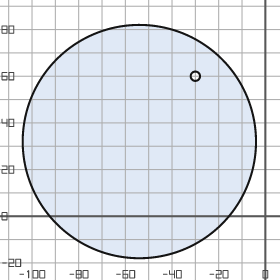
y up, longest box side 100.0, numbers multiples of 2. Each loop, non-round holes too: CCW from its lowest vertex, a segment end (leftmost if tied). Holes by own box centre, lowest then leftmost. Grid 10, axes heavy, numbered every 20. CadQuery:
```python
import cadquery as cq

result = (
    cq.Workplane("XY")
    .moveTo(-54.0, 32.0)
    .circle(50.0)
    .moveTo(-30.0, 60.0)
    .circle(2.0)
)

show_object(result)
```